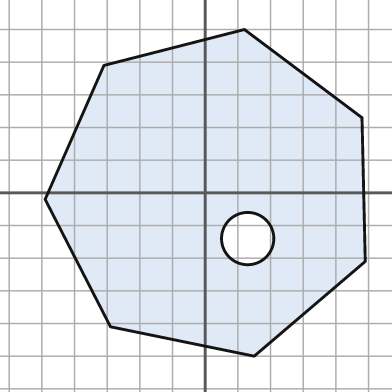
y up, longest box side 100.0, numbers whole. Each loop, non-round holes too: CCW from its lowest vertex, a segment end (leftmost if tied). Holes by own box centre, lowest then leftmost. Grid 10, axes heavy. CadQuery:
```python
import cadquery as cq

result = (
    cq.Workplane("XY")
    .moveTo(15.0, -50.0)
    .lineTo(49.0, -21.0)
    .lineTo(48.0, 23.0)
    .lineTo(12.0, 50.0)
    .lineTo(-31.0, 39.0)
    .lineTo(-49.0, -2.0)
    .lineTo(-29.0, -41.0)
    .close()
    .moveTo(13.0, -14.0)
    .circle(8.0)
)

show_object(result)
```